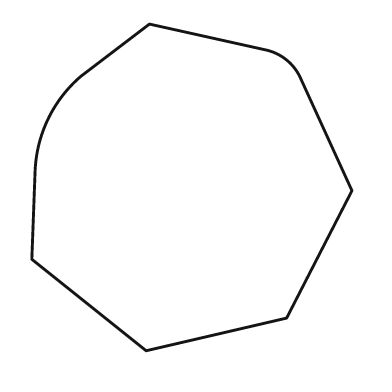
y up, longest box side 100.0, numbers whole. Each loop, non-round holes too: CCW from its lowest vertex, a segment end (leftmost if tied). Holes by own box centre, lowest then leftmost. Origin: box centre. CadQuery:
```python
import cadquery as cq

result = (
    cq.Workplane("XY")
    .moveTo(-14.0, -50.0)
    .lineTo(29.0, -40.0)
    .lineTo(49.0, -1.0)
    .lineTo(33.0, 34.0)
    .threePointArc((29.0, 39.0), (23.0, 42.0))
    .lineTo(-13.0, 50.0)
    .lineTo(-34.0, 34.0)
    .threePointArc((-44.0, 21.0), (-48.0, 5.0))
    .lineTo(-49.0, -22.0)
    .close()
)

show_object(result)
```